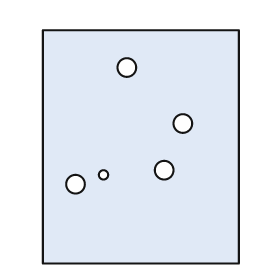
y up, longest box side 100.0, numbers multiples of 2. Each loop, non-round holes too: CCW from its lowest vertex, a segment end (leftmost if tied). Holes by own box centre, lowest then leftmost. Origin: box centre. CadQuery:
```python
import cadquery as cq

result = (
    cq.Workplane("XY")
    .moveTo(-42.0, -50.0)
    .lineTo(42.0, -50.0)
    .lineTo(42.0, 50.0)
    .lineTo(-42.0, 50.0)
    .close()
    .moveTo(-28.0, -16.0)
    .circle(4.0)
    .moveTo(-16.0, -12.0)
    .circle(2.0)
    .moveTo(10.0, -10.0)
    .circle(4.0)
    .moveTo(18.0, 10.0)
    .circle(4.0)
    .moveTo(-6.0, 34.0)
    .circle(4.0)
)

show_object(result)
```